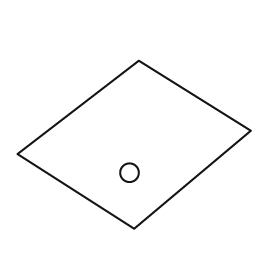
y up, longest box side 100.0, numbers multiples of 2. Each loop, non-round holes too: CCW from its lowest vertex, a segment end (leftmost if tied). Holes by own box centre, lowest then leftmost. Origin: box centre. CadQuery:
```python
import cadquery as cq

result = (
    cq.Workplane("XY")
    .moveTo(0.0, -36.0)
    .lineTo(50.0, 6.0)
    .lineTo(2.0, 36.0)
    .lineTo(-50.0, -4.0)
    .close()
    .moveTo(-2.0, -12.0)
    .circle(4.0)
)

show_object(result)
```